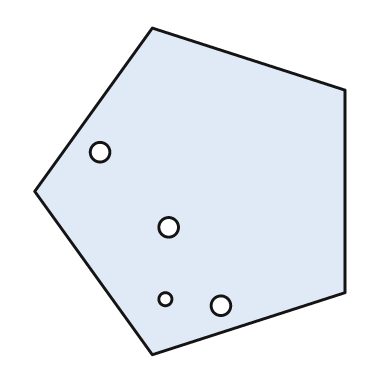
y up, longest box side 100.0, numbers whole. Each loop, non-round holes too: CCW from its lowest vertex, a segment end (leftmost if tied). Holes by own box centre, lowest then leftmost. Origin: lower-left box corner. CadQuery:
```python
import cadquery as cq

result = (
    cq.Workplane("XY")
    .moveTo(36.0, 0.0)
    .lineTo(95.0, 19.0)
    .lineTo(95.0, 81.0)
    .lineTo(36.0, 100.0)
    .lineTo(0.0, 50.0)
    .close()
    .moveTo(57.0, 15.0)
    .circle(3.0)
    .moveTo(40.0, 17.0)
    .circle(2.0)
    .moveTo(41.0, 39.0)
    .circle(3.0)
    .moveTo(20.0, 62.0)
    .circle(3.0)
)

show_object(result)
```